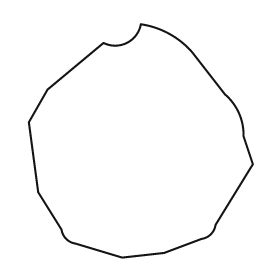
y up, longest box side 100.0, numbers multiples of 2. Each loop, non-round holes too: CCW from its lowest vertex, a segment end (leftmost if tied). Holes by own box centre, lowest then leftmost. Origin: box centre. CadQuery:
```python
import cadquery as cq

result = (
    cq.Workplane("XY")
    .moveTo(-8.0, -50.0)
    .lineTo(10.0, -48.0)
    .lineTo(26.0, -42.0)
    .threePointArc((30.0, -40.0), (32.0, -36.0))
    .lineTo(48.0, -10.0)
    .lineTo(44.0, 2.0)
    .threePointArc((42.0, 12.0), (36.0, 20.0))
    .lineTo(22.0, 38.0)
    .threePointArc((12.0, 46.0), (0.0, 50.0))
    .threePointArc((-6.0, 42.0), (-16.0, 42.0))
    .lineTo(-40.0, 22.0)
    .lineTo(-48.0, 8.0)
    .lineTo(-44.0, -22.0)
    .lineTo(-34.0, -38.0)
    .threePointArc((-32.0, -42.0), (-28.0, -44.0))
    .close()
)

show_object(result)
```